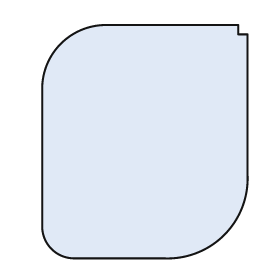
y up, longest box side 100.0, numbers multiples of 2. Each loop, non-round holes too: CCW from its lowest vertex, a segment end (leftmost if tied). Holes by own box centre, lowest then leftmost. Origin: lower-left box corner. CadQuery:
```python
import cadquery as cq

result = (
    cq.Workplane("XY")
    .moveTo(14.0, 0.0)
    .lineTo(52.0, 0.0)
    .threePointArc((78.0, 10.0), (88.0, 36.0))
    .lineTo(88.0, 96.0)
    .lineTo(84.0, 96.0)
    .lineTo(84.0, 100.0)
    .lineTo(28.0, 100.0)
    .threePointArc((8.0, 92.0), (0.0, 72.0))
    .lineTo(0.0, 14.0)
    .threePointArc((4.0, 4.0), (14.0, 0.0))
    .close()
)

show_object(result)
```